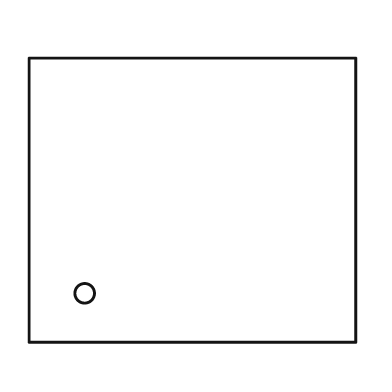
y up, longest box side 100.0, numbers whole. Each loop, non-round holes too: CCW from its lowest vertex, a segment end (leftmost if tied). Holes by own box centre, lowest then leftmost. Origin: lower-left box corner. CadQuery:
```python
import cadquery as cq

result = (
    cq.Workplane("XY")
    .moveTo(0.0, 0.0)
    .lineTo(100.0, 0.0)
    .lineTo(100.0, 87.0)
    .lineTo(0.0, 87.0)
    .close()
    .moveTo(17.0, 15.0)
    .circle(3.0)
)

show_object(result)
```